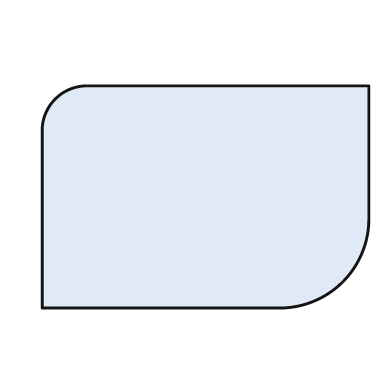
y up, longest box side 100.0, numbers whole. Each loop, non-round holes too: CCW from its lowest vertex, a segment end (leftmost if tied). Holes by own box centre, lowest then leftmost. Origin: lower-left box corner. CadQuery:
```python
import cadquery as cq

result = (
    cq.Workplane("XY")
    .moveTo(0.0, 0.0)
    .lineTo(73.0, 0.0)
    .threePointArc((92.0, 8.0), (100.0, 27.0))
    .lineTo(100.0, 68.0)
    .lineTo(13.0, 68.0)
    .threePointArc((4.0, 64.0), (0.0, 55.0))
    .close()
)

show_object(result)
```